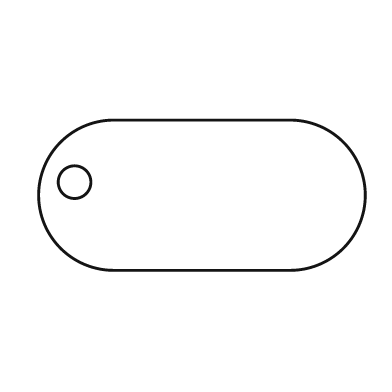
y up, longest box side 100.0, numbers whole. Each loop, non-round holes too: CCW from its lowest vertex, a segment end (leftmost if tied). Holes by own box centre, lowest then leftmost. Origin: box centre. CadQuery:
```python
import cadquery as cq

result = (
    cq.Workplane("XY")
    .moveTo(-27.0, -23.0)
    .lineTo(27.0, -23.0)
    .threePointArc((50.0, 0.0), (27.0, 23.0))
    .lineTo(-27.0, 23.0)
    .threePointArc((-50.0, 0.0), (-27.0, -23.0))
    .close()
    .moveTo(-39.0, 4.0)
    .circle(5.0)
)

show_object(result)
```